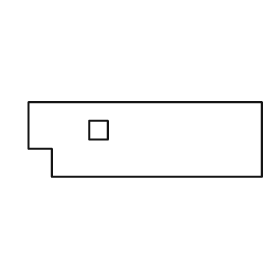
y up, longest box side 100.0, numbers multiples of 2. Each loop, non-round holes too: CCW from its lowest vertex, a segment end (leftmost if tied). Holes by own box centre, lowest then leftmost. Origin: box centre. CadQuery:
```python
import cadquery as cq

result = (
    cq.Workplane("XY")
    .moveTo(-40.0, -16.0)
    .lineTo(50.0, -16.0)
    .lineTo(50.0, 16.0)
    .lineTo(-50.0, 16.0)
    .lineTo(-50.0, -4.0)
    .lineTo(-40.0, -4.0)
    .close()
    .moveTo(-24.0, 0.0)
    .lineTo(-16.0, 0.0)
    .lineTo(-16.0, 8.0)
    .lineTo(-24.0, 8.0)
    .close()
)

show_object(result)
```